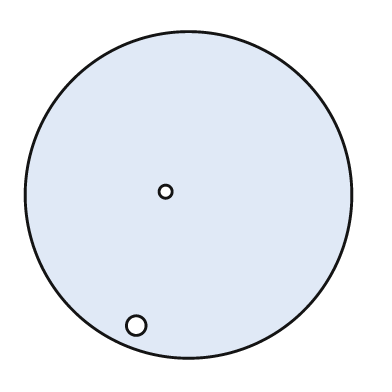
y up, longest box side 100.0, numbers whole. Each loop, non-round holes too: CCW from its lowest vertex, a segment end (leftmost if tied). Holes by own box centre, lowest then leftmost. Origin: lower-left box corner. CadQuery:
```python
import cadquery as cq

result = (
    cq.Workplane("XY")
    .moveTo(50.0, 50.0)
    .circle(50.0)
    .moveTo(34.0, 10.0)
    .circle(3.0)
    .moveTo(43.0, 51.0)
    .circle(2.0)
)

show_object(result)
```